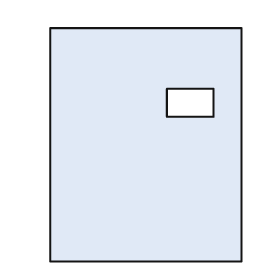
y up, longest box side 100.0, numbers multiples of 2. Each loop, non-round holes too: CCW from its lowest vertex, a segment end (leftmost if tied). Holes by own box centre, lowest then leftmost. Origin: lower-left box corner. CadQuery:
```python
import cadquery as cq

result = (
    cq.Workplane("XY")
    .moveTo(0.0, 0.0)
    .lineTo(82.0, 0.0)
    .lineTo(82.0, 100.0)
    .lineTo(0.0, 100.0)
    .close()
    .moveTo(50.0, 62.0)
    .lineTo(70.0, 62.0)
    .lineTo(70.0, 74.0)
    .lineTo(50.0, 74.0)
    .close()
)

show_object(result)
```